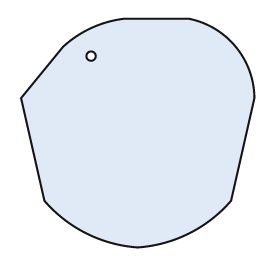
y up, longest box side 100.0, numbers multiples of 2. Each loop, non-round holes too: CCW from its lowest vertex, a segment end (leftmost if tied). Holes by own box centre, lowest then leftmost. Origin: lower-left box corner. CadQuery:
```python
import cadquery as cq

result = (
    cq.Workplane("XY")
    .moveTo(50.0, 0.0)
    .threePointArc((72.0, 6.0), (90.0, 20.0))
    .lineTo(100.0, 64.0)
    .threePointArc((92.0, 86.0), (72.0, 98.0))
    .lineTo(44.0, 98.0)
    .threePointArc((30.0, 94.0), (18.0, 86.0))
    .lineTo(0.0, 64.0)
    .lineTo(10.0, 20.0)
    .threePointArc((28.0, 6.0), (50.0, 0.0))
    .close()
    .moveTo(30.0, 82.0)
    .circle(2.0)
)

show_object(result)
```